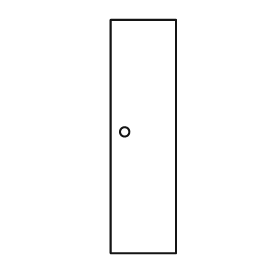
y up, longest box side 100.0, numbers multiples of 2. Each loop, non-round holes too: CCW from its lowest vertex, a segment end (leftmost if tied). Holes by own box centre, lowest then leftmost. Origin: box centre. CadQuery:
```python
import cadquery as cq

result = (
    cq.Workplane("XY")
    .moveTo(-14.0, -50.0)
    .lineTo(14.0, -50.0)
    .lineTo(14.0, 50.0)
    .lineTo(-14.0, 50.0)
    .close()
    .moveTo(-8.0, 2.0)
    .circle(2.0)
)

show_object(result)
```